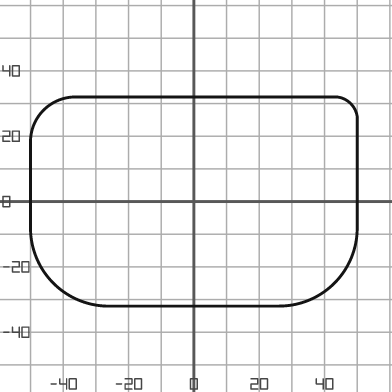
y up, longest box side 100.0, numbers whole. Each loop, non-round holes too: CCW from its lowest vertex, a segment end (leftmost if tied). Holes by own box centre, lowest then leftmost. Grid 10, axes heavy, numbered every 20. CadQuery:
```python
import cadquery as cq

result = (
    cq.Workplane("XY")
    .moveTo(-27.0, -32.0)
    .lineTo(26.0, -32.0)
    .threePointArc((43.0, -25.0), (50.0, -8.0))
    .lineTo(50.0, 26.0)
    .threePointArc((48.0, 30.0), (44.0, 32.0))
    .lineTo(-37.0, 32.0)
    .threePointArc((-46.0, 28.0), (-50.0, 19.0))
    .lineTo(-50.0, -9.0)
    .threePointArc((-43.0, -25.0), (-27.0, -32.0))
    .close()
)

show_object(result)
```